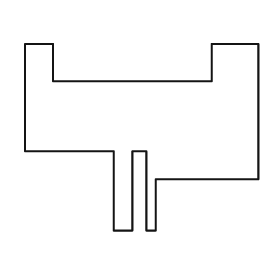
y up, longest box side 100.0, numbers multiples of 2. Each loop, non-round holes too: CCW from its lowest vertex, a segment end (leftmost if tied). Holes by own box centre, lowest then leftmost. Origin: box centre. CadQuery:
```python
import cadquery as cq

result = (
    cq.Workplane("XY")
    .moveTo(-12.0, -40.0)
    .lineTo(-4.0, -40.0)
    .lineTo(-4.0, -6.0)
    .lineTo(2.0, -6.0)
    .lineTo(2.0, -40.0)
    .lineTo(6.0, -40.0)
    .lineTo(6.0, -18.0)
    .lineTo(50.0, -18.0)
    .lineTo(50.0, 40.0)
    .lineTo(30.0, 40.0)
    .lineTo(30.0, 24.0)
    .lineTo(-38.0, 24.0)
    .lineTo(-38.0, 40.0)
    .lineTo(-50.0, 40.0)
    .lineTo(-50.0, -6.0)
    .lineTo(-12.0, -6.0)
    .close()
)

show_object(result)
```